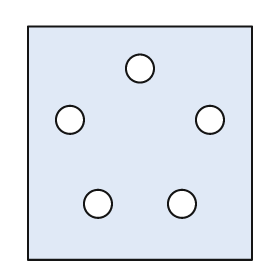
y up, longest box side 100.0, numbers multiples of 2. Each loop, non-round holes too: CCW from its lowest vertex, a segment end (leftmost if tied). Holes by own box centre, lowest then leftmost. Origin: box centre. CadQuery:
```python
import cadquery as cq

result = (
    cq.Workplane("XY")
    .moveTo(-48.0, -50.0)
    .lineTo(48.0, -50.0)
    .lineTo(48.0, 50.0)
    .lineTo(-48.0, 50.0)
    .close()
    .moveTo(-18.0, -26.0)
    .circle(6.0)
    .moveTo(18.0, -26.0)
    .circle(6.0)
    .moveTo(-30.0, 10.0)
    .circle(6.0)
    .moveTo(30.0, 10.0)
    .circle(6.0)
    .moveTo(0.0, 32.0)
    .circle(6.0)
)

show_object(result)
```